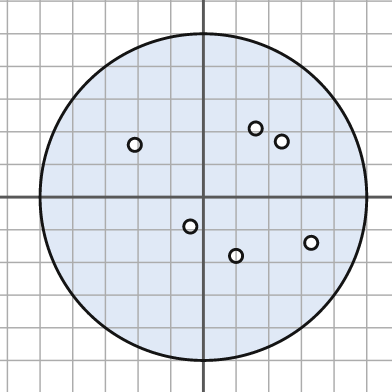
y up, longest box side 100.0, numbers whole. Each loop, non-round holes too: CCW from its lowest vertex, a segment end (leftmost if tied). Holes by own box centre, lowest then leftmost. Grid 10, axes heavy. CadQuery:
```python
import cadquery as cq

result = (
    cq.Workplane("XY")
    .moveTo(0.0, 0.0)
    .circle(50.0)
    .moveTo(10.0, -18.0)
    .circle(2.0)
    .moveTo(33.0, -14.0)
    .circle(2.0)
    .moveTo(-4.0, -9.0)
    .circle(2.0)
    .moveTo(-21.0, 16.0)
    .circle(2.0)
    .moveTo(24.0, 17.0)
    .circle(2.0)
    .moveTo(16.0, 21.0)
    .circle(2.0)
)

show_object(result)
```